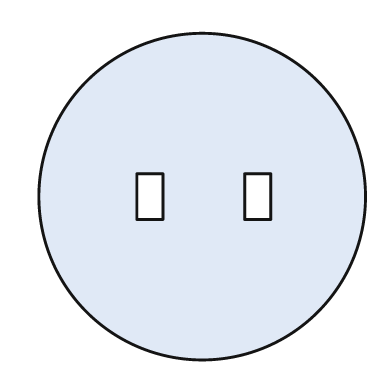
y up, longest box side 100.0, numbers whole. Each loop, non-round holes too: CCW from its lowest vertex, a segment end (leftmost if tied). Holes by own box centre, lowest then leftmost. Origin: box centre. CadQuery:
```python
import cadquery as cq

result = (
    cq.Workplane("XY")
    .moveTo(0.0, 0.0)
    .circle(50.0)
    .moveTo(-20.0, -7.0)
    .lineTo(-12.0, -7.0)
    .lineTo(-12.0, 7.0)
    .lineTo(-20.0, 7.0)
    .close()
    .moveTo(13.0, -7.0)
    .lineTo(21.0, -7.0)
    .lineTo(21.0, 7.0)
    .lineTo(13.0, 7.0)
    .close()
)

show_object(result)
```